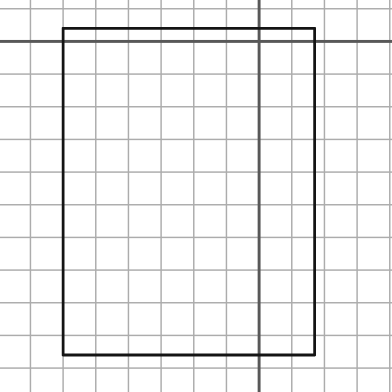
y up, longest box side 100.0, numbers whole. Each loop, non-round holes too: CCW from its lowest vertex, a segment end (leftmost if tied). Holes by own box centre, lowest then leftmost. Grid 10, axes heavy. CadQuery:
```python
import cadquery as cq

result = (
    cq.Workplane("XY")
    .moveTo(-60.0, -96.0)
    .lineTo(17.0, -96.0)
    .lineTo(17.0, 4.0)
    .lineTo(-60.0, 4.0)
    .close()
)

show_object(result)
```